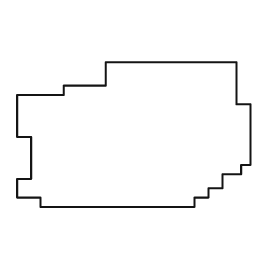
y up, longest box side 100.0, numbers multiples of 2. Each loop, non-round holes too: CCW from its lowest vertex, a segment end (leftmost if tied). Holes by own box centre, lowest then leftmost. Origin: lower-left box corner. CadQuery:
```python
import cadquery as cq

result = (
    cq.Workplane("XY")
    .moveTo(10.0, 0.0)
    .lineTo(76.0, 0.0)
    .lineTo(76.0, 4.0)
    .lineTo(82.0, 4.0)
    .lineTo(82.0, 8.0)
    .lineTo(88.0, 8.0)
    .lineTo(88.0, 14.0)
    .lineTo(96.0, 14.0)
    .lineTo(96.0, 18.0)
    .lineTo(100.0, 18.0)
    .lineTo(100.0, 44.0)
    .lineTo(94.0, 44.0)
    .lineTo(94.0, 62.0)
    .lineTo(38.0, 62.0)
    .lineTo(38.0, 52.0)
    .lineTo(20.0, 52.0)
    .lineTo(20.0, 48.0)
    .lineTo(0.0, 48.0)
    .lineTo(0.0, 30.0)
    .lineTo(6.0, 30.0)
    .lineTo(6.0, 12.0)
    .lineTo(0.0, 12.0)
    .lineTo(0.0, 4.0)
    .lineTo(10.0, 4.0)
    .close()
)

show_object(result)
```